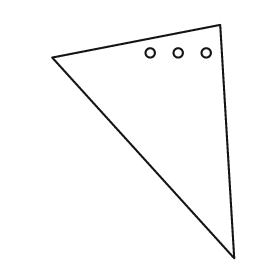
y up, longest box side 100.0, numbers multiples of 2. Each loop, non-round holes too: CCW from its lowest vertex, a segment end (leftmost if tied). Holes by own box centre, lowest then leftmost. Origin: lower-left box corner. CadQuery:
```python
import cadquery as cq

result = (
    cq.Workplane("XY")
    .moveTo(78.0, 0.0)
    .lineTo(72.0, 100.0)
    .lineTo(0.0, 86.0)
    .close()
    .moveTo(42.0, 88.0)
    .circle(2.0)
    .moveTo(54.0, 88.0)
    .circle(2.0)
    .moveTo(66.0, 88.0)
    .circle(2.0)
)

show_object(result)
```